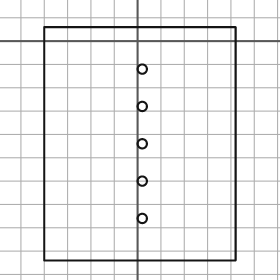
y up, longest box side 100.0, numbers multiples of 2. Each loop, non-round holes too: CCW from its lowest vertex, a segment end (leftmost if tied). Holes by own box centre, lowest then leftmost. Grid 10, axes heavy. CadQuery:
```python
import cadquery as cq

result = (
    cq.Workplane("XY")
    .moveTo(-40.0, -94.0)
    .lineTo(42.0, -94.0)
    .lineTo(42.0, 6.0)
    .lineTo(-40.0, 6.0)
    .close()
    .moveTo(2.0, -76.0)
    .circle(2.0)
    .moveTo(2.0, -60.0)
    .circle(2.0)
    .moveTo(2.0, -44.0)
    .circle(2.0)
    .moveTo(2.0, -28.0)
    .circle(2.0)
    .moveTo(2.0, -12.0)
    .circle(2.0)
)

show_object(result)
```